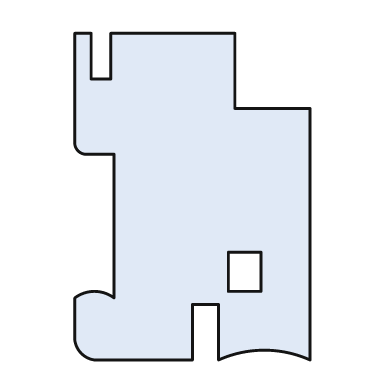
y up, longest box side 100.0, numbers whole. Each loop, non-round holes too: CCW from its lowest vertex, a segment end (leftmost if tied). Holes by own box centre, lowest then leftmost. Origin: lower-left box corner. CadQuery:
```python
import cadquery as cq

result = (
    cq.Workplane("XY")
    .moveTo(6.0, 0.0)
    .lineTo(36.0, 0.0)
    .lineTo(36.0, 17.0)
    .lineTo(44.0, 17.0)
    .lineTo(44.0, 0.0)
    .threePointArc((58.0, 3.0), (72.0, 0.0))
    .lineTo(72.0, 77.0)
    .lineTo(49.0, 77.0)
    .lineTo(49.0, 100.0)
    .lineTo(11.0, 100.0)
    .lineTo(11.0, 86.0)
    .lineTo(5.0, 86.0)
    .lineTo(5.0, 100.0)
    .lineTo(0.0, 100.0)
    .lineTo(0.0, 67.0)
    .threePointArc((1.0, 64.0), (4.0, 63.0))
    .lineTo(12.0, 63.0)
    .lineTo(12.0, 19.0)
    .threePointArc((6.0, 21.0), (0.0, 19.0))
    .lineTo(0.0, 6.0)
    .threePointArc((2.0, 2.0), (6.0, 0.0))
    .close()
    .moveTo(47.0, 21.0)
    .lineTo(57.0, 21.0)
    .lineTo(57.0, 33.0)
    .lineTo(47.0, 33.0)
    .close()
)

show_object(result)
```